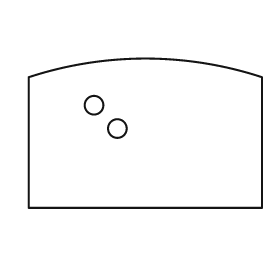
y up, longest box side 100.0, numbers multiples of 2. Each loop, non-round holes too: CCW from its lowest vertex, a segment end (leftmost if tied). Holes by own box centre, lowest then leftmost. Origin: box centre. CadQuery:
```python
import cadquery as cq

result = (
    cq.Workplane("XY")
    .moveTo(-50.0, -32.0)
    .lineTo(50.0, -32.0)
    .lineTo(50.0, 24.0)
    .threePointArc((0.0, 32.0), (-50.0, 24.0))
    .close()
    .moveTo(-12.0, 2.0)
    .circle(4.0)
    .moveTo(-22.0, 12.0)
    .circle(4.0)
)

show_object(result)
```